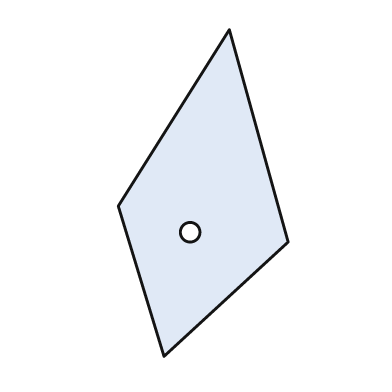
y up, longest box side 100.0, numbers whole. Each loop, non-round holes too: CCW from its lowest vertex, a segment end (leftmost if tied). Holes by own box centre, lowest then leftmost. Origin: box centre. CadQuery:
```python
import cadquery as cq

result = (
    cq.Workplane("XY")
    .moveTo(-12.0, -50.0)
    .lineTo(26.0, -15.0)
    .lineTo(8.0, 50.0)
    .lineTo(-26.0, -4.0)
    .close()
    .moveTo(-4.0, -12.0)
    .circle(3.0)
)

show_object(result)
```